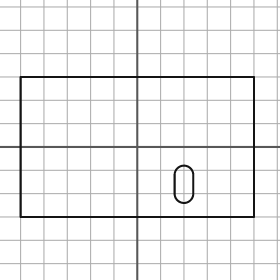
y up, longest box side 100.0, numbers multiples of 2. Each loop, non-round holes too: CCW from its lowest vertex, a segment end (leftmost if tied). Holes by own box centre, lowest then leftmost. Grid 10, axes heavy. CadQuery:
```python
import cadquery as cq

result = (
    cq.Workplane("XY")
    .moveTo(-50.0, -30.0)
    .lineTo(50.0, -30.0)
    .lineTo(50.0, 30.0)
    .lineTo(-50.0, 30.0)
    .close()
    .moveTo(16.0, -20.0)
    .threePointArc((20.0, -24.0), (24.0, -20.0))
    .lineTo(24.0, -12.0)
    .threePointArc((20.0, -8.0), (16.0, -12.0))
    .close()
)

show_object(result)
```